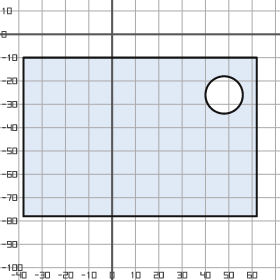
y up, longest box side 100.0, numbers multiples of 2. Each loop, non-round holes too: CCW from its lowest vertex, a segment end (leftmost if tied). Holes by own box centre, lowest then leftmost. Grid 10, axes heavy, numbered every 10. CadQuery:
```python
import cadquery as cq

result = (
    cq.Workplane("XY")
    .moveTo(-38.0, -78.0)
    .lineTo(62.0, -78.0)
    .lineTo(62.0, -10.0)
    .lineTo(-38.0, -10.0)
    .close()
    .moveTo(48.0, -26.0)
    .circle(8.0)
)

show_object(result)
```